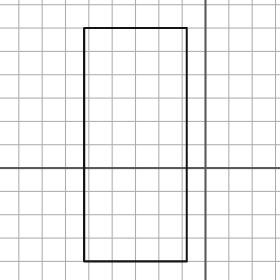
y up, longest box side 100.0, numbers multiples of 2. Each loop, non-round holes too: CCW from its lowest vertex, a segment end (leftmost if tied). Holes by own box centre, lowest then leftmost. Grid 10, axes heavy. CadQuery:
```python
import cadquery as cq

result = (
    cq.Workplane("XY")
    .moveTo(-52.0, -40.0)
    .lineTo(-8.0, -40.0)
    .lineTo(-8.0, 60.0)
    .lineTo(-52.0, 60.0)
    .close()
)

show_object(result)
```